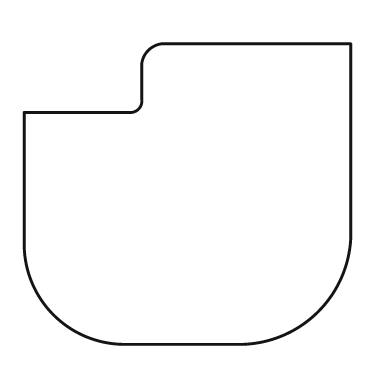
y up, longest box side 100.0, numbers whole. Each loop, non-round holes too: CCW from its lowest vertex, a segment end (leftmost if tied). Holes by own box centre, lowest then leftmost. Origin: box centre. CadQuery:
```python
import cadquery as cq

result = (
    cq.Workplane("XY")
    .moveTo(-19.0, -46.0)
    .lineTo(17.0, -46.0)
    .threePointArc((40.0, -36.0), (50.0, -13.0))
    .lineTo(50.0, 46.0)
    .lineTo(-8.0, 46.0)
    .threePointArc((-12.0, 44.0), (-14.0, 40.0))
    .lineTo(-14.0, 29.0)
    .threePointArc((-15.0, 26.0), (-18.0, 25.0))
    .lineTo(-50.0, 25.0)
    .lineTo(-50.0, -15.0)
    .threePointArc((-41.0, -37.0), (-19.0, -46.0))
    .close()
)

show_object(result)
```